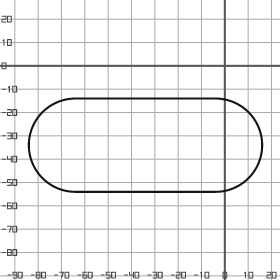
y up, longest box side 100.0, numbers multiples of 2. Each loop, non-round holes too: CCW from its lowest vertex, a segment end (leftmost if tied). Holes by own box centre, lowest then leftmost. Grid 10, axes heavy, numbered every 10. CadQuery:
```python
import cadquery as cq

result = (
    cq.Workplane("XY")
    .moveTo(-64.0, -54.0)
    .lineTo(-4.0, -54.0)
    .threePointArc((16.0, -34.0), (-4.0, -14.0))
    .lineTo(-64.0, -14.0)
    .threePointArc((-84.0, -34.0), (-64.0, -54.0))
    .close()
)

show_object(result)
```